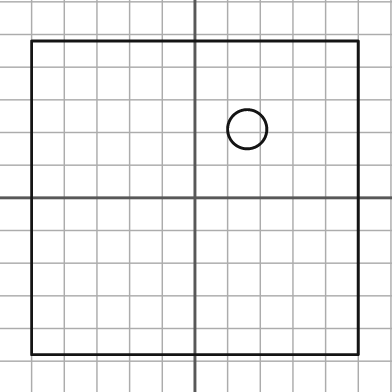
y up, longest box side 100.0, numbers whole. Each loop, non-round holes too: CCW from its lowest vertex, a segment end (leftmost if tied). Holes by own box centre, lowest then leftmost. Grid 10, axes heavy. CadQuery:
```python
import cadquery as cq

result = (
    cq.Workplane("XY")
    .moveTo(-50.0, -48.0)
    .lineTo(50.0, -48.0)
    .lineTo(50.0, 48.0)
    .lineTo(-50.0, 48.0)
    .close()
    .moveTo(16.0, 21.0)
    .circle(6.0)
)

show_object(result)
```